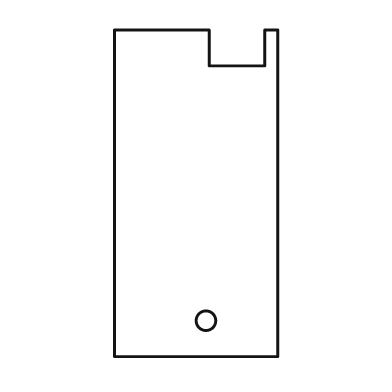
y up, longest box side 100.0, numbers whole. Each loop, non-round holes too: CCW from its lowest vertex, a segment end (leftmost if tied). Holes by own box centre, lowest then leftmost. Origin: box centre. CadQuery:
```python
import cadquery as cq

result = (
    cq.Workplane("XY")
    .moveTo(-25.0, -50.0)
    .lineTo(25.0, -50.0)
    .lineTo(25.0, 50.0)
    .lineTo(21.0, 50.0)
    .lineTo(21.0, 39.0)
    .lineTo(4.0, 39.0)
    .lineTo(4.0, 50.0)
    .lineTo(-25.0, 50.0)
    .close()
    .moveTo(3.0, -39.0)
    .circle(3.0)
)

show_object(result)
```